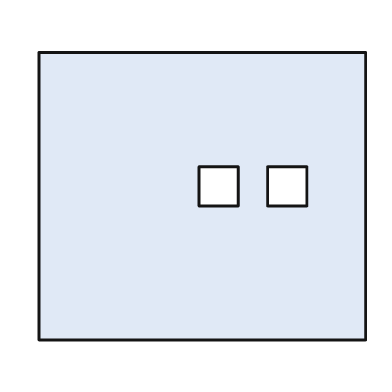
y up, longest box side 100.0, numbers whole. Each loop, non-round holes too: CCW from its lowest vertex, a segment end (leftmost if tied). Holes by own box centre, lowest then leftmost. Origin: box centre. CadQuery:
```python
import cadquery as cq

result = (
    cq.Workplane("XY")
    .moveTo(-50.0, -44.0)
    .lineTo(50.0, -44.0)
    .lineTo(50.0, 44.0)
    .lineTo(-50.0, 44.0)
    .close()
    .moveTo(-1.0, -3.0)
    .lineTo(11.0, -3.0)
    .lineTo(11.0, 9.0)
    .lineTo(-1.0, 9.0)
    .close()
    .moveTo(20.0, -3.0)
    .lineTo(32.0, -3.0)
    .lineTo(32.0, 9.0)
    .lineTo(20.0, 9.0)
    .close()
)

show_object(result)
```